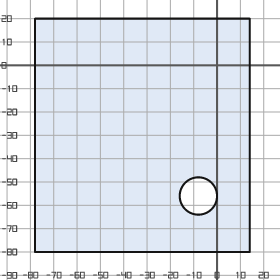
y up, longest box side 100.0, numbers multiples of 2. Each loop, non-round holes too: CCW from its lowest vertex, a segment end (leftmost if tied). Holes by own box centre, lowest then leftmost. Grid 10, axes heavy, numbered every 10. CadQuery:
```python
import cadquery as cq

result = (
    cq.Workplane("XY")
    .moveTo(-78.0, -80.0)
    .lineTo(14.0, -80.0)
    .lineTo(14.0, 20.0)
    .lineTo(-78.0, 20.0)
    .close()
    .moveTo(-8.0, -56.0)
    .circle(8.0)
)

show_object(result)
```